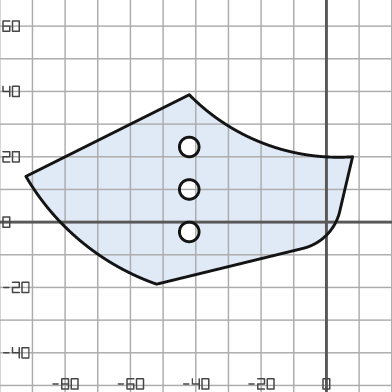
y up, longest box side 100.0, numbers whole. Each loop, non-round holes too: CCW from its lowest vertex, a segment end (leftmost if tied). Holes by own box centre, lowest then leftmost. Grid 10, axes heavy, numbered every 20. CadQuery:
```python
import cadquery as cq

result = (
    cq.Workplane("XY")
    .moveTo(-52.0, -19.0)
    .lineTo(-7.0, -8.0)
    .threePointArc((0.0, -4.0), (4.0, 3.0))
    .lineTo(8.0, 20.0)
    .threePointArc((-19.0, 24.0), (-42.0, 39.0))
    .lineTo(-92.0, 14.0)
    .threePointArc((-75.0, -6.0), (-52.0, -19.0))
    .close()
    .moveTo(-42.0, -3.0)
    .circle(3.0)
    .moveTo(-42.0, 10.0)
    .circle(3.0)
    .moveTo(-42.0, 23.0)
    .circle(3.0)
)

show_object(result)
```